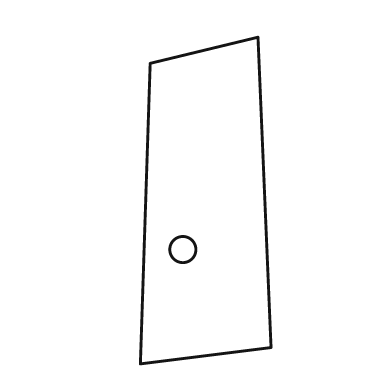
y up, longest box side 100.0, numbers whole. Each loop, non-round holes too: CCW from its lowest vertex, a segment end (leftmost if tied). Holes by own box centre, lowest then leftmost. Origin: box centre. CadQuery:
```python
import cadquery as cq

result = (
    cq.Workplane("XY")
    .moveTo(-20.0, -50.0)
    .lineTo(20.0, -45.0)
    .lineTo(16.0, 50.0)
    .lineTo(-17.0, 42.0)
    .close()
    .moveTo(-7.0, -15.0)
    .circle(4.0)
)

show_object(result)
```